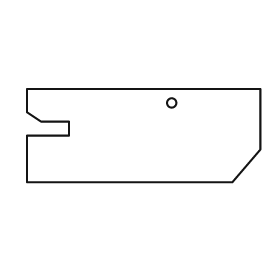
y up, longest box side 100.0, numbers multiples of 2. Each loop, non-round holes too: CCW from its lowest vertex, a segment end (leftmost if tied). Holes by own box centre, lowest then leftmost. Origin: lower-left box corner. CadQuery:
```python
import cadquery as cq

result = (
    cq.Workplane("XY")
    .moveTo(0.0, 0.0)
    .lineTo(88.0, 0.0)
    .lineTo(100.0, 14.0)
    .lineTo(100.0, 40.0)
    .lineTo(0.0, 40.0)
    .lineTo(0.0, 30.0)
    .lineTo(6.0, 26.0)
    .lineTo(18.0, 26.0)
    .lineTo(18.0, 20.0)
    .lineTo(0.0, 20.0)
    .close()
    .moveTo(62.0, 34.0)
    .circle(2.0)
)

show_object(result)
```